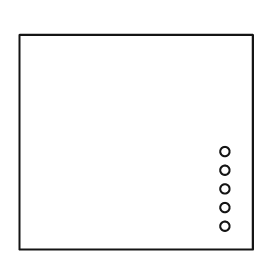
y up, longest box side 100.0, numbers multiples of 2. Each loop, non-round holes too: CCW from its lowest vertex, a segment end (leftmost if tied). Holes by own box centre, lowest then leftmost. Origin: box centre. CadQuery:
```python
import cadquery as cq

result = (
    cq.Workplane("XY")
    .moveTo(-50.0, -46.0)
    .lineTo(50.0, -46.0)
    .lineTo(50.0, 46.0)
    .lineTo(-50.0, 46.0)
    .close()
    .moveTo(38.0, -36.0)
    .circle(2.0)
    .moveTo(38.0, -28.0)
    .circle(2.0)
    .moveTo(38.0, -20.0)
    .circle(2.0)
    .moveTo(38.0, -12.0)
    .circle(2.0)
    .moveTo(38.0, -4.0)
    .circle(2.0)
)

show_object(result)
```